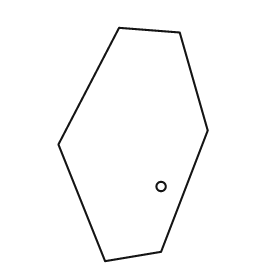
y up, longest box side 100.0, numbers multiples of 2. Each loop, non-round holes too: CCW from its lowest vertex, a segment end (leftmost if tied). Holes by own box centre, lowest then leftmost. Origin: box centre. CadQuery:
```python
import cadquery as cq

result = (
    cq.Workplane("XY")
    .moveTo(-12.0, -50.0)
    .lineTo(12.0, -46.0)
    .lineTo(32.0, 6.0)
    .lineTo(20.0, 48.0)
    .lineTo(-6.0, 50.0)
    .lineTo(-32.0, 0.0)
    .close()
    .moveTo(12.0, -18.0)
    .circle(2.0)
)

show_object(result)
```